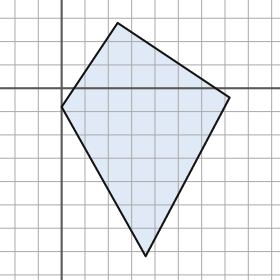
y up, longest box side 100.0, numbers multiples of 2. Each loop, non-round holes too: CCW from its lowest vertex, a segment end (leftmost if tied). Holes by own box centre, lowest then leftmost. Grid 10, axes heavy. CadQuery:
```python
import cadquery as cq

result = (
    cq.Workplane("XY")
    .moveTo(36.0, -72.0)
    .lineTo(72.0, -4.0)
    .lineTo(24.0, 28.0)
    .lineTo(0.0, -8.0)
    .close()
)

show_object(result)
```